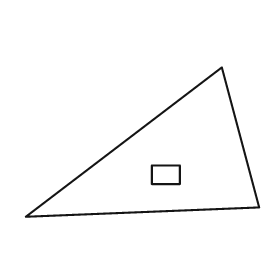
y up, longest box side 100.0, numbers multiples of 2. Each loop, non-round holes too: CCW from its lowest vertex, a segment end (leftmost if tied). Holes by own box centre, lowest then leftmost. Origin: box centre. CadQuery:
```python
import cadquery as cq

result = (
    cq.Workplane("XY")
    .moveTo(-50.0, -32.0)
    .lineTo(50.0, -28.0)
    .lineTo(34.0, 32.0)
    .close()
    .moveTo(4.0, -18.0)
    .lineTo(16.0, -18.0)
    .lineTo(16.0, -10.0)
    .lineTo(4.0, -10.0)
    .close()
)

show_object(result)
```